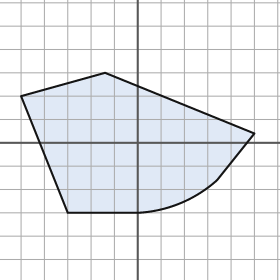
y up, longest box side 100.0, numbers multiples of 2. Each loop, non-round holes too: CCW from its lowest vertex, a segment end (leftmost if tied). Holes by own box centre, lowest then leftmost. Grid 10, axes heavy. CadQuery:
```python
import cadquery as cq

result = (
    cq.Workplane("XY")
    .moveTo(-30.0, -30.0)
    .lineTo(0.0, -30.0)
    .threePointArc((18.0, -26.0), (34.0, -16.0))
    .lineTo(50.0, 4.0)
    .lineTo(-14.0, 30.0)
    .lineTo(-50.0, 20.0)
    .close()
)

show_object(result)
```